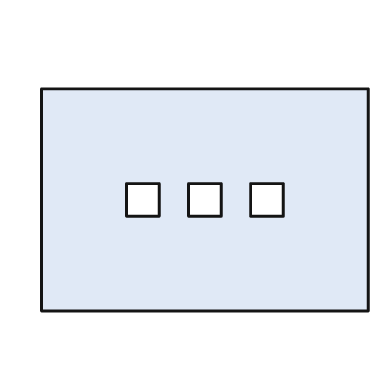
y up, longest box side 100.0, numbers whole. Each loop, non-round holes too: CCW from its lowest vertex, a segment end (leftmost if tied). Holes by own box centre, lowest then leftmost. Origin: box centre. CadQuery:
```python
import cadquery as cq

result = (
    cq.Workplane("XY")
    .moveTo(-50.0, -34.0)
    .lineTo(50.0, -34.0)
    .lineTo(50.0, 34.0)
    .lineTo(-50.0, 34.0)
    .close()
    .moveTo(-24.0, -5.0)
    .lineTo(-14.0, -5.0)
    .lineTo(-14.0, 5.0)
    .lineTo(-24.0, 5.0)
    .close()
    .moveTo(-5.0, -5.0)
    .lineTo(5.0, -5.0)
    .lineTo(5.0, 5.0)
    .lineTo(-5.0, 5.0)
    .close()
    .moveTo(14.0, -5.0)
    .lineTo(24.0, -5.0)
    .lineTo(24.0, 5.0)
    .lineTo(14.0, 5.0)
    .close()
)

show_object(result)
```